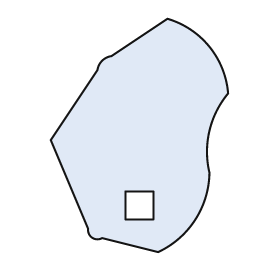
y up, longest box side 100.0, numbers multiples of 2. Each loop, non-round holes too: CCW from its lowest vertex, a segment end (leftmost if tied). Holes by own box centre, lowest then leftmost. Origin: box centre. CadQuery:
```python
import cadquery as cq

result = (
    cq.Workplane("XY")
    .moveTo(8.0, -50.0)
    .threePointArc((24.0, -36.0), (30.0, -16.0))
    .threePointArc((30.0, 2.0), (38.0, 18.0))
    .threePointArc((30.0, 38.0), (12.0, 50.0))
    .lineTo(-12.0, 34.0)
    .threePointArc((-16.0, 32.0), (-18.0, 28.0))
    .lineTo(-38.0, -2.0)
    .lineTo(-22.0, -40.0)
    .threePointArc((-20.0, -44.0), (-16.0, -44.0))
    .close()
    .moveTo(-6.0, -36.0)
    .lineTo(6.0, -36.0)
    .lineTo(6.0, -24.0)
    .lineTo(-6.0, -24.0)
    .close()
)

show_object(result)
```